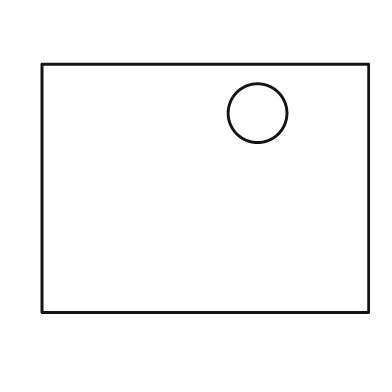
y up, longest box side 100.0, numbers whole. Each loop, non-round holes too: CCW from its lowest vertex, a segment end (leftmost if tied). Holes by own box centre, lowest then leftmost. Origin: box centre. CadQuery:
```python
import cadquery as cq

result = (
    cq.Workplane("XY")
    .moveTo(-50.0, -38.0)
    .lineTo(50.0, -38.0)
    .lineTo(50.0, 38.0)
    .lineTo(-50.0, 38.0)
    .close()
    .moveTo(16.0, 23.0)
    .circle(9.0)
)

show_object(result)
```